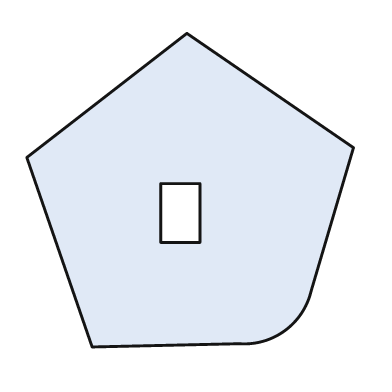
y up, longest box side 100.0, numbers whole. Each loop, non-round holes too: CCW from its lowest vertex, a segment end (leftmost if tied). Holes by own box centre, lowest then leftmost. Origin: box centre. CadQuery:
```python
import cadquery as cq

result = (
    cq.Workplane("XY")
    .moveTo(-30.0, -48.0)
    .lineTo(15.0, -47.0)
    .threePointArc((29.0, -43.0), (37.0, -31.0))
    .lineTo(50.0, 13.0)
    .lineTo(-1.0, 48.0)
    .lineTo(-50.0, 10.0)
    .close()
    .moveTo(-9.0, -16.0)
    .lineTo(3.0, -16.0)
    .lineTo(3.0, 2.0)
    .lineTo(-9.0, 2.0)
    .close()
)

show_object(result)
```